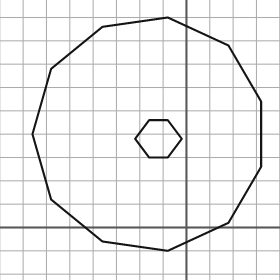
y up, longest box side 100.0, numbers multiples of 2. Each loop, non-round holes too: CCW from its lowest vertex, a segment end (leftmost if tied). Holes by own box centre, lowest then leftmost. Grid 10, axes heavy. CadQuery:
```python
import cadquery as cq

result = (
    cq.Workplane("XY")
    .moveTo(-8.0, -10.0)
    .lineTo(18.0, 2.0)
    .lineTo(32.0, 26.0)
    .lineTo(32.0, 54.0)
    .lineTo(18.0, 78.0)
    .lineTo(-8.0, 90.0)
    .lineTo(-36.0, 86.0)
    .lineTo(-58.0, 68.0)
    .lineTo(-66.0, 40.0)
    .lineTo(-58.0, 12.0)
    .lineTo(-36.0, -6.0)
    .close()
    .moveTo(-16.0, 30.0)
    .lineTo(-8.0, 30.0)
    .lineTo(-2.0, 38.0)
    .lineTo(-8.0, 46.0)
    .lineTo(-16.0, 46.0)
    .lineTo(-22.0, 38.0)
    .close()
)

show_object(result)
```